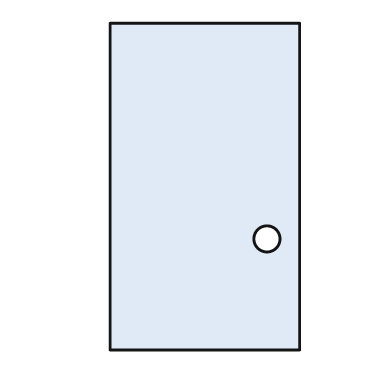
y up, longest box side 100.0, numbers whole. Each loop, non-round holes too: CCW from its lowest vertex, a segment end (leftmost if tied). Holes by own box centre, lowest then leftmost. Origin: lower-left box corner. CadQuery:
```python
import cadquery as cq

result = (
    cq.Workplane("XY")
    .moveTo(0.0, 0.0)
    .lineTo(58.0, 0.0)
    .lineTo(58.0, 100.0)
    .lineTo(0.0, 100.0)
    .close()
    .moveTo(48.0, 34.0)
    .circle(4.0)
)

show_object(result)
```